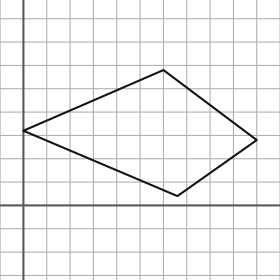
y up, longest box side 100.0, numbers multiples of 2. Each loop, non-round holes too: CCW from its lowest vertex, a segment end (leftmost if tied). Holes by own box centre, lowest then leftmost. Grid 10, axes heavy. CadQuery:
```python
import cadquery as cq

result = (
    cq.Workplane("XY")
    .moveTo(66.0, 4.0)
    .lineTo(100.0, 28.0)
    .lineTo(60.0, 58.0)
    .lineTo(0.0, 32.0)
    .close()
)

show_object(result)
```